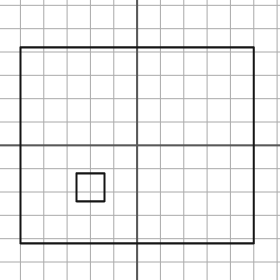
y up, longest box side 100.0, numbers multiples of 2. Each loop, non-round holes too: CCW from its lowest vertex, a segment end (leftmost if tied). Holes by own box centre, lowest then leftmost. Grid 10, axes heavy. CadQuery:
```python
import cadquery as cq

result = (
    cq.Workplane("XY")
    .moveTo(-50.0, -42.0)
    .lineTo(50.0, -42.0)
    .lineTo(50.0, 42.0)
    .lineTo(-50.0, 42.0)
    .close()
    .moveTo(-26.0, -24.0)
    .lineTo(-14.0, -24.0)
    .lineTo(-14.0, -12.0)
    .lineTo(-26.0, -12.0)
    .close()
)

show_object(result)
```